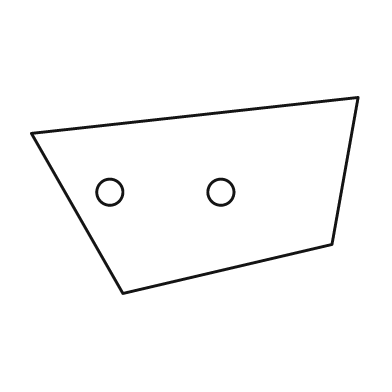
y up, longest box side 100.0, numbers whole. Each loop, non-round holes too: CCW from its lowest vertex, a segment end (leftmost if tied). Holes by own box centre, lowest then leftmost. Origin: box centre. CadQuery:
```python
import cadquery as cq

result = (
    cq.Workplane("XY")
    .moveTo(-22.0, -30.0)
    .lineTo(42.0, -15.0)
    .lineTo(50.0, 30.0)
    .lineTo(-50.0, 19.0)
    .close()
    .moveTo(-26.0, 1.0)
    .circle(4.0)
    .moveTo(8.0, 1.0)
    .circle(4.0)
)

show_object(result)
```